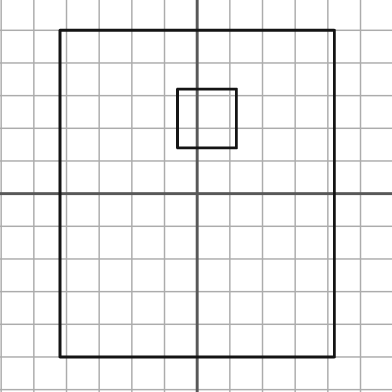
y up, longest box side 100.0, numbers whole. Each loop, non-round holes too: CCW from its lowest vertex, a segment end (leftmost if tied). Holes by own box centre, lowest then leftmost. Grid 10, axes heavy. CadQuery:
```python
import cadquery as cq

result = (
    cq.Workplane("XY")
    .moveTo(-42.0, -50.0)
    .lineTo(42.0, -50.0)
    .lineTo(42.0, 50.0)
    .lineTo(-42.0, 50.0)
    .close()
    .moveTo(-6.0, 14.0)
    .lineTo(12.0, 14.0)
    .lineTo(12.0, 32.0)
    .lineTo(-6.0, 32.0)
    .close()
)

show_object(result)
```